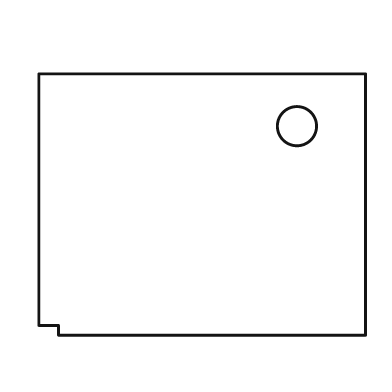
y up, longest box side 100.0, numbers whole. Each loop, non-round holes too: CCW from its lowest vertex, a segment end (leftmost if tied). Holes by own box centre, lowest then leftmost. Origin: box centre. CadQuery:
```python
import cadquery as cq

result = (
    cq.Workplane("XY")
    .moveTo(-44.0, -40.0)
    .lineTo(50.0, -40.0)
    .lineTo(50.0, 40.0)
    .lineTo(-50.0, 40.0)
    .lineTo(-50.0, -37.0)
    .lineTo(-44.0, -37.0)
    .close()
    .moveTo(29.0, 24.0)
    .circle(6.0)
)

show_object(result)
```